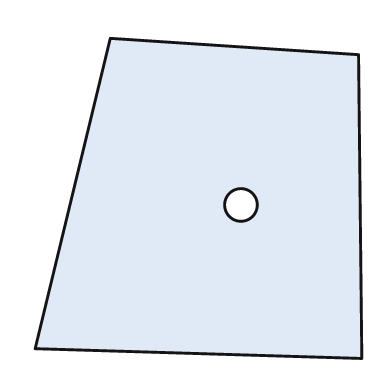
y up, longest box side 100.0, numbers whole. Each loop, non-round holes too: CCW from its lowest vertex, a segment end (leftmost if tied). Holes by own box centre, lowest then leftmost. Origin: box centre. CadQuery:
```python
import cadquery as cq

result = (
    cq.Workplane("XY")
    .moveTo(50.0, -49.0)
    .lineTo(49.0, 44.0)
    .lineTo(-27.0, 49.0)
    .lineTo(-50.0, -46.0)
    .close()
    .moveTo(13.0, -2.0)
    .circle(5.0)
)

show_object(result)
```